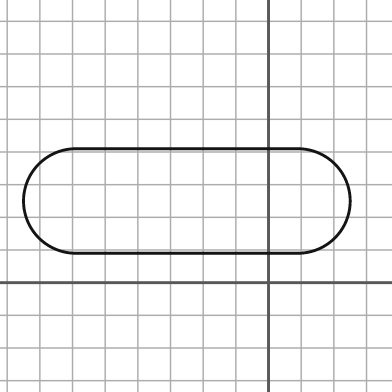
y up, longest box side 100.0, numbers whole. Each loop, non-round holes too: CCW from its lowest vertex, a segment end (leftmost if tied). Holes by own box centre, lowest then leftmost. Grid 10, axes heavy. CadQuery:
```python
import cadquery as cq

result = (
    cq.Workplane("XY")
    .moveTo(-59.0, 9.0)
    .lineTo(9.0, 9.0)
    .threePointArc((25.0, 25.0), (9.0, 41.0))
    .lineTo(-59.0, 41.0)
    .threePointArc((-75.0, 25.0), (-59.0, 9.0))
    .close()
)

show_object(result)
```